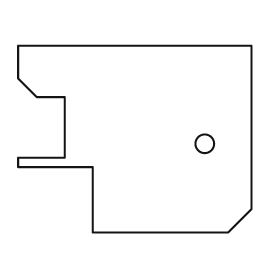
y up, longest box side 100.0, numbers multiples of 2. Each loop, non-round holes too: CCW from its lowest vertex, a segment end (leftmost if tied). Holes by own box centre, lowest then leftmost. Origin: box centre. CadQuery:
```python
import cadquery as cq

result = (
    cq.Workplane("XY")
    .moveTo(-18.0, -40.0)
    .lineTo(40.0, -40.0)
    .lineTo(50.0, -30.0)
    .lineTo(50.0, 40.0)
    .lineTo(-50.0, 40.0)
    .lineTo(-50.0, 26.0)
    .lineTo(-42.0, 18.0)
    .lineTo(-30.0, 18.0)
    .lineTo(-30.0, -8.0)
    .lineTo(-50.0, -8.0)
    .lineTo(-50.0, -12.0)
    .lineTo(-18.0, -12.0)
    .close()
    .moveTo(30.0, -2.0)
    .circle(4.0)
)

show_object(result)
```